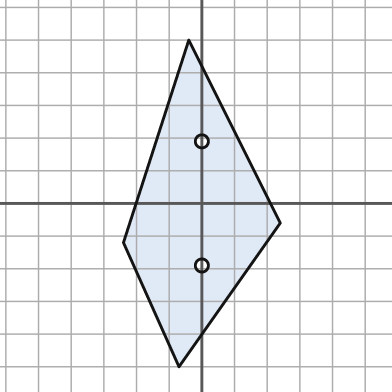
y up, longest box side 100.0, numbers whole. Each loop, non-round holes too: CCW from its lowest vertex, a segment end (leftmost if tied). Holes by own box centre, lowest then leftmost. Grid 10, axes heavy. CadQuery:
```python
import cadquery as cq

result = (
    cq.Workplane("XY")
    .moveTo(-7.0, -50.0)
    .lineTo(24.0, -6.0)
    .lineTo(-4.0, 50.0)
    .lineTo(-24.0, -12.0)
    .close()
    .moveTo(0.0, -19.0)
    .circle(2.0)
    .moveTo(0.0, 19.0)
    .circle(2.0)
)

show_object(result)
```